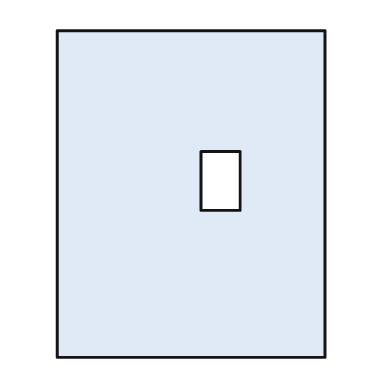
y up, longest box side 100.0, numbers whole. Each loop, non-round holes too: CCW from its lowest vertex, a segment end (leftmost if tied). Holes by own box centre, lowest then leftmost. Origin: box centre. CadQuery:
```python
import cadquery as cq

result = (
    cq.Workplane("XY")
    .moveTo(-41.0, -50.0)
    .lineTo(41.0, -50.0)
    .lineTo(41.0, 50.0)
    .lineTo(-41.0, 50.0)
    .close()
    .moveTo(3.0, -5.0)
    .lineTo(15.0, -5.0)
    .lineTo(15.0, 13.0)
    .lineTo(3.0, 13.0)
    .close()
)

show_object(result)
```